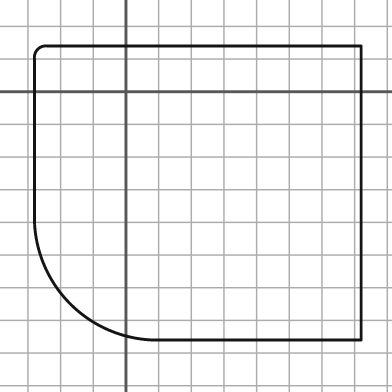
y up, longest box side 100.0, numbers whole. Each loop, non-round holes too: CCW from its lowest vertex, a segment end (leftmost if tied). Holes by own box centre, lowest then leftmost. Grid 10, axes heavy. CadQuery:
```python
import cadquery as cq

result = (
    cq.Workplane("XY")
    .moveTo(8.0, -76.0)
    .lineTo(72.0, -76.0)
    .lineTo(72.0, 14.0)
    .lineTo(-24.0, 14.0)
    .threePointArc((-27.0, 13.0), (-28.0, 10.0))
    .lineTo(-28.0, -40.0)
    .threePointArc((-17.0, -65.0), (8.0, -76.0))
    .close()
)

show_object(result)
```